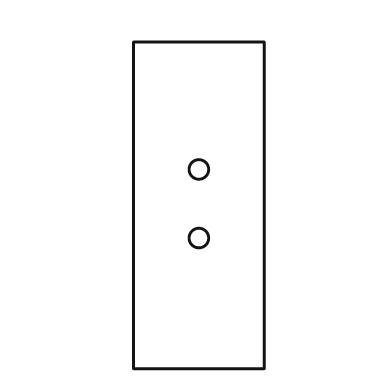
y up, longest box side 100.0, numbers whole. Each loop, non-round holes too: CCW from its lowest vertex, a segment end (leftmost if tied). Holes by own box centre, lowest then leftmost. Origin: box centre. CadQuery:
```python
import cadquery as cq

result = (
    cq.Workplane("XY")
    .moveTo(-20.0, -50.0)
    .lineTo(20.0, -50.0)
    .lineTo(20.0, 50.0)
    .lineTo(-20.0, 50.0)
    .close()
    .moveTo(0.0, -10.0)
    .circle(3.0)
    .moveTo(0.0, 11.0)
    .circle(3.0)
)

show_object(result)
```